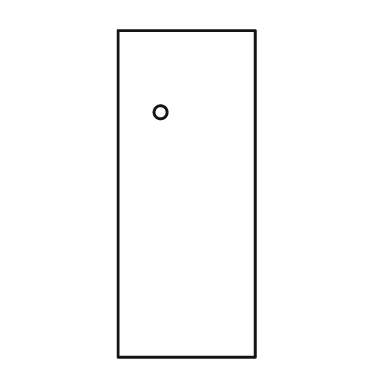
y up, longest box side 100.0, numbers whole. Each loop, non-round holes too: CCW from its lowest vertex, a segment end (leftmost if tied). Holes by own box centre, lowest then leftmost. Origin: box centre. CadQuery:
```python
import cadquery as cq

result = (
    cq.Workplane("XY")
    .moveTo(-21.0, -50.0)
    .lineTo(21.0, -50.0)
    .lineTo(21.0, 50.0)
    .lineTo(-21.0, 50.0)
    .close()
    .moveTo(-8.0, 25.0)
    .circle(2.0)
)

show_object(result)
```